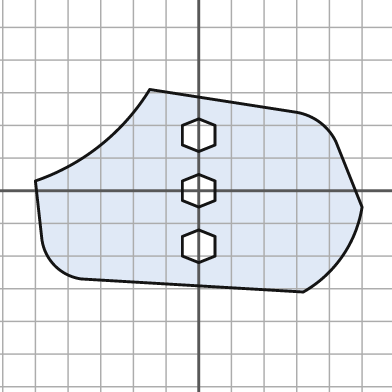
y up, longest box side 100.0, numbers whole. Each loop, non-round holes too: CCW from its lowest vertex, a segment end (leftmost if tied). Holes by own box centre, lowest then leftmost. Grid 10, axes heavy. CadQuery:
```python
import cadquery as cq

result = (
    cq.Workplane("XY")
    .moveTo(32.0, -31.0)
    .threePointArc((44.0, -20.0), (50.0, -5.0))
    .lineTo(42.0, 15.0)
    .threePointArc((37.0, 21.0), (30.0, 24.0))
    .lineTo(-15.0, 31.0)
    .threePointArc((-30.0, 14.0), (-50.0, 3.0))
    .lineTo(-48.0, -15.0)
    .threePointArc((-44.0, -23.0), (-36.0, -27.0))
    .close()
    .moveTo(0.0, -22.0)
    .lineTo(5.0, -20.0)
    .lineTo(5.0, -14.0)
    .lineTo(0.0, -12.0)
    .lineTo(-5.0, -14.0)
    .lineTo(-5.0, -20.0)
    .close()
    .moveTo(0.0, -5.0)
    .lineTo(5.0, -3.0)
    .lineTo(5.0, 3.0)
    .lineTo(0.0, 5.0)
    .lineTo(-5.0, 3.0)
    .lineTo(-5.0, -3.0)
    .close()
    .moveTo(0.0, 12.0)
    .lineTo(5.0, 14.0)
    .lineTo(5.0, 20.0)
    .lineTo(0.0, 22.0)
    .lineTo(-5.0, 20.0)
    .lineTo(-5.0, 14.0)
    .close()
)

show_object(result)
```